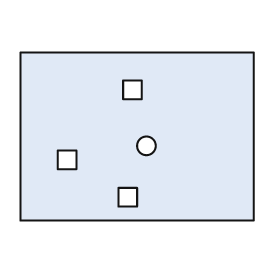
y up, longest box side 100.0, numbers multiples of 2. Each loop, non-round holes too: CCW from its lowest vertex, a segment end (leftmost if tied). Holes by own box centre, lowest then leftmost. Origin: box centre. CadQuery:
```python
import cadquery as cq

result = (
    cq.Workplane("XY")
    .moveTo(-50.0, -36.0)
    .lineTo(50.0, -36.0)
    .lineTo(50.0, 36.0)
    .lineTo(-50.0, 36.0)
    .close()
    .moveTo(-8.0, -30.0)
    .lineTo(0.0, -30.0)
    .lineTo(0.0, -22.0)
    .lineTo(-8.0, -22.0)
    .close()
    .moveTo(-34.0, -14.0)
    .lineTo(-26.0, -14.0)
    .lineTo(-26.0, -6.0)
    .lineTo(-34.0, -6.0)
    .close()
    .moveTo(4.0, -4.0)
    .circle(4.0)
    .moveTo(-6.0, 16.0)
    .lineTo(2.0, 16.0)
    .lineTo(2.0, 24.0)
    .lineTo(-6.0, 24.0)
    .close()
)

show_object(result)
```